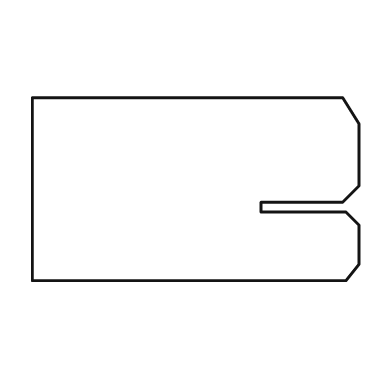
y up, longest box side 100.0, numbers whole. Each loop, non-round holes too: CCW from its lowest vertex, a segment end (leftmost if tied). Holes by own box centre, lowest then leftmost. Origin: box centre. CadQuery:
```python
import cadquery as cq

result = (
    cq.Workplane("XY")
    .moveTo(-50.0, -28.0)
    .lineTo(46.0, -28.0)
    .lineTo(50.0, -23.0)
    .lineTo(50.0, -11.0)
    .lineTo(46.0, -7.0)
    .lineTo(20.0, -7.0)
    .lineTo(20.0, -4.0)
    .lineTo(45.0, -4.0)
    .lineTo(50.0, 1.0)
    .lineTo(50.0, 20.0)
    .lineTo(45.0, 28.0)
    .lineTo(-50.0, 28.0)
    .close()
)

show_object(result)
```